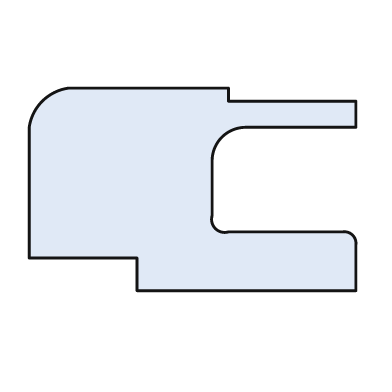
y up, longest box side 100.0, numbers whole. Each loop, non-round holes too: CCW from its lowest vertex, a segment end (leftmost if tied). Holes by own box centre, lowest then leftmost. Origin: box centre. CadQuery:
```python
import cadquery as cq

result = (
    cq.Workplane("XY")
    .moveTo(-17.0, -31.0)
    .lineTo(50.0, -31.0)
    .lineTo(50.0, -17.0)
    .threePointArc((49.0, -14.0), (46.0, -13.0))
    .lineTo(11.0, -13.0)
    .threePointArc((7.0, -12.0), (6.0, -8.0))
    .lineTo(6.0, 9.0)
    .threePointArc((9.0, 16.0), (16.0, 19.0))
    .lineTo(50.0, 19.0)
    .lineTo(50.0, 27.0)
    .lineTo(11.0, 27.0)
    .lineTo(11.0, 31.0)
    .lineTo(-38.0, 31.0)
    .threePointArc((-46.0, 27.0), (-50.0, 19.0))
    .lineTo(-50.0, -21.0)
    .lineTo(-17.0, -21.0)
    .close()
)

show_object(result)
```